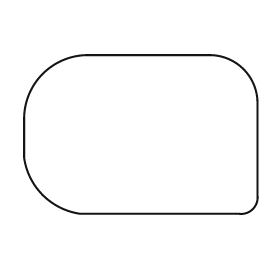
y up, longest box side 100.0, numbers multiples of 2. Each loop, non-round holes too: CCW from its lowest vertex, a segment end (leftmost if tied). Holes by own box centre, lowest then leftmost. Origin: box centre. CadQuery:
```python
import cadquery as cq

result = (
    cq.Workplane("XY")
    .moveTo(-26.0, -34.0)
    .lineTo(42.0, -34.0)
    .threePointArc((48.0, -32.0), (50.0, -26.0))
    .lineTo(50.0, 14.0)
    .threePointArc((44.0, 28.0), (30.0, 34.0))
    .lineTo(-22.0, 34.0)
    .threePointArc((-42.0, 26.0), (-50.0, 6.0))
    .lineTo(-50.0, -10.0)
    .threePointArc((-42.0, -26.0), (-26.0, -34.0))
    .close()
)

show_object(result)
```